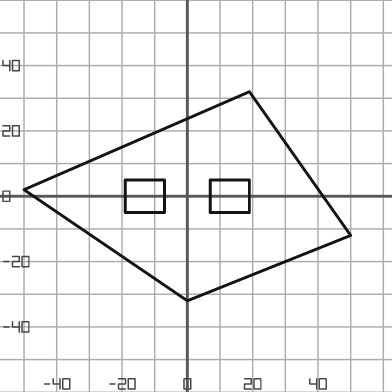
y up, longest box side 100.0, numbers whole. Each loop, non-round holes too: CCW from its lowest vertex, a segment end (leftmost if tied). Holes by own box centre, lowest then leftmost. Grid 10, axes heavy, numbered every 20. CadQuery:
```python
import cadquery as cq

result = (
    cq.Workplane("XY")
    .moveTo(0.0, -32.0)
    .lineTo(50.0, -12.0)
    .lineTo(19.0, 32.0)
    .lineTo(-50.0, 2.0)
    .close()
    .moveTo(-19.0, -5.0)
    .lineTo(-7.0, -5.0)
    .lineTo(-7.0, 5.0)
    .lineTo(-19.0, 5.0)
    .close()
    .moveTo(7.0, -5.0)
    .lineTo(19.0, -5.0)
    .lineTo(19.0, 5.0)
    .lineTo(7.0, 5.0)
    .close()
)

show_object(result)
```